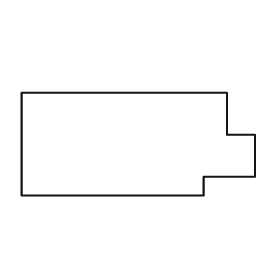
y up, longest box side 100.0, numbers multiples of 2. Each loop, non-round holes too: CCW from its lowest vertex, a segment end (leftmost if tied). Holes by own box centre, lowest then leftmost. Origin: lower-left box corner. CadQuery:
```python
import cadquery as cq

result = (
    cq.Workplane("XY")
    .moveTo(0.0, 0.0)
    .lineTo(78.0, 0.0)
    .lineTo(78.0, 8.0)
    .lineTo(100.0, 8.0)
    .lineTo(100.0, 26.0)
    .lineTo(88.0, 26.0)
    .lineTo(88.0, 44.0)
    .lineTo(0.0, 44.0)
    .close()
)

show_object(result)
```